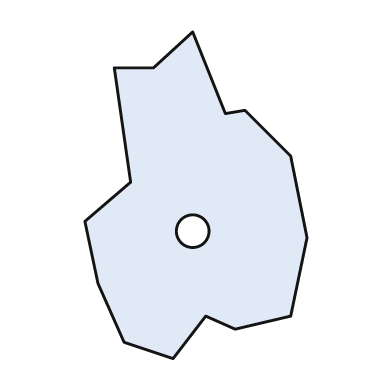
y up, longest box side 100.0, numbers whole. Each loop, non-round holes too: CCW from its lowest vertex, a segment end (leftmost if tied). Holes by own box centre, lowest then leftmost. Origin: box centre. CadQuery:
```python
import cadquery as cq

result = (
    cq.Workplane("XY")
    .moveTo(-7.0, -50.0)
    .lineTo(3.0, -37.0)
    .lineTo(12.0, -41.0)
    .lineTo(29.0, -37.0)
    .lineTo(34.0, -13.0)
    .lineTo(29.0, 12.0)
    .lineTo(15.0, 26.0)
    .lineTo(9.0, 25.0)
    .lineTo(-1.0, 50.0)
    .lineTo(-13.0, 39.0)
    .lineTo(-25.0, 39.0)
    .lineTo(-20.0, 4.0)
    .lineTo(-34.0, -8.0)
    .lineTo(-30.0, -27.0)
    .lineTo(-22.0, -45.0)
    .close()
    .moveTo(-1.0, -11.0)
    .circle(5.0)
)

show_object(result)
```